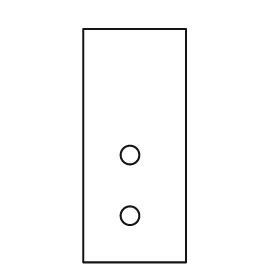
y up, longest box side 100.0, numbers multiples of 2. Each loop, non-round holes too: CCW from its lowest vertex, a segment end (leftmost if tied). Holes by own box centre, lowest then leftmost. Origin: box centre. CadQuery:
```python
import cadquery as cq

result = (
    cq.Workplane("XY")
    .moveTo(-22.0, -50.0)
    .lineTo(22.0, -50.0)
    .lineTo(22.0, 50.0)
    .lineTo(-22.0, 50.0)
    .close()
    .moveTo(-2.0, -30.0)
    .circle(4.0)
    .moveTo(-2.0, -4.0)
    .circle(4.0)
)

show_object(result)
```